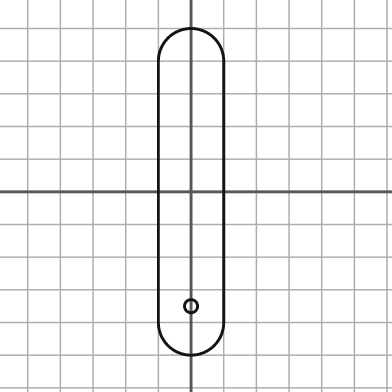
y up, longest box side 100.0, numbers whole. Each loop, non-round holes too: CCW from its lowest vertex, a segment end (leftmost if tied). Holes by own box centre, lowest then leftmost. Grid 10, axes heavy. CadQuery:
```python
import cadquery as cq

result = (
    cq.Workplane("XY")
    .moveTo(-10.0, -40.0)
    .threePointArc((0.0, -50.0), (10.0, -40.0))
    .lineTo(10.0, 40.0)
    .threePointArc((0.0, 50.0), (-10.0, 40.0))
    .close()
    .moveTo(0.0, -35.0)
    .circle(2.0)
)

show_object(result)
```